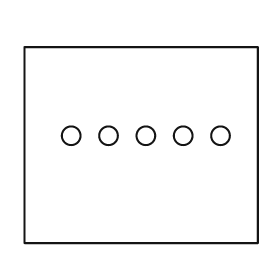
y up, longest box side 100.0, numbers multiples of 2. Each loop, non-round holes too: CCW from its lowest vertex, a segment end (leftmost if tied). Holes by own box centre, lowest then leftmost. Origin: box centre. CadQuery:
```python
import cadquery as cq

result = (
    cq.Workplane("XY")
    .moveTo(-50.0, -42.0)
    .lineTo(50.0, -42.0)
    .lineTo(50.0, 42.0)
    .lineTo(-50.0, 42.0)
    .close()
    .moveTo(-30.0, 4.0)
    .circle(4.0)
    .moveTo(-14.0, 4.0)
    .circle(4.0)
    .moveTo(2.0, 4.0)
    .circle(4.0)
    .moveTo(18.0, 4.0)
    .circle(4.0)
    .moveTo(34.0, 4.0)
    .circle(4.0)
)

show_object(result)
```